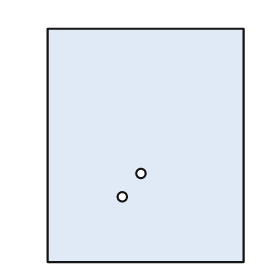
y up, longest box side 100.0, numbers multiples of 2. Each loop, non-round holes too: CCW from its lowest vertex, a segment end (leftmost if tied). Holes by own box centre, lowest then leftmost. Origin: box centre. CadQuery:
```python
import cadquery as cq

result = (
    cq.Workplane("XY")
    .moveTo(-42.0, -50.0)
    .lineTo(42.0, -50.0)
    .lineTo(42.0, 50.0)
    .lineTo(-42.0, 50.0)
    .close()
    .moveTo(-10.0, -22.0)
    .circle(2.0)
    .moveTo(-2.0, -12.0)
    .circle(2.0)
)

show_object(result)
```